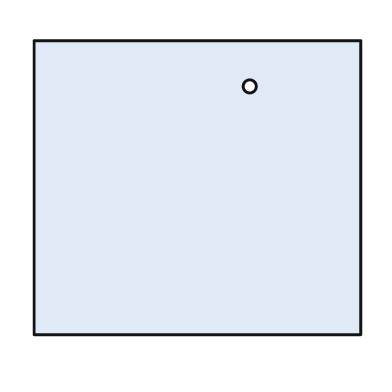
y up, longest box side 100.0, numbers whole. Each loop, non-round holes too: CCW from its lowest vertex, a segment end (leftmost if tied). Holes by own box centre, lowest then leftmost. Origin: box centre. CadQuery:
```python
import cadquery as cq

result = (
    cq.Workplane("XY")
    .moveTo(-50.0, -45.0)
    .lineTo(50.0, -45.0)
    .lineTo(50.0, 45.0)
    .lineTo(-50.0, 45.0)
    .close()
    .moveTo(16.0, 31.0)
    .circle(2.0)
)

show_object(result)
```